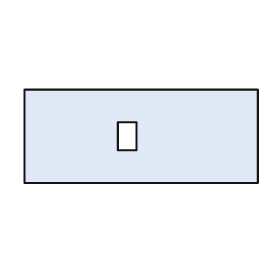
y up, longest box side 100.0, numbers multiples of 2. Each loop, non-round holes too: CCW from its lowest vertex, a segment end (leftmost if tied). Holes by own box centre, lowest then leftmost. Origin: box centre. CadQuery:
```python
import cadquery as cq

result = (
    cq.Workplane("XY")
    .moveTo(-50.0, -20.0)
    .lineTo(50.0, -20.0)
    .lineTo(50.0, 20.0)
    .lineTo(-50.0, 20.0)
    .close()
    .moveTo(-10.0, -6.0)
    .lineTo(-2.0, -6.0)
    .lineTo(-2.0, 6.0)
    .lineTo(-10.0, 6.0)
    .close()
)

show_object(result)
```